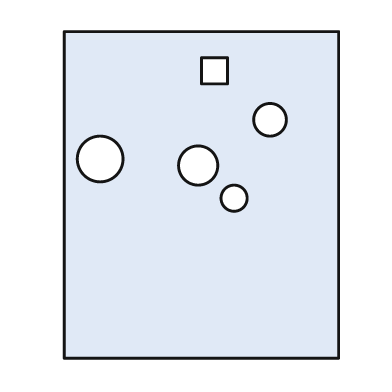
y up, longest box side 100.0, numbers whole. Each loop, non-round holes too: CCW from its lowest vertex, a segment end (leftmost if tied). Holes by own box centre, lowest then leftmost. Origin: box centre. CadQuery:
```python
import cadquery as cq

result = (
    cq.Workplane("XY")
    .moveTo(-42.0, -50.0)
    .lineTo(42.0, -50.0)
    .lineTo(42.0, 50.0)
    .lineTo(-42.0, 50.0)
    .close()
    .moveTo(10.0, -1.0)
    .circle(4.0)
    .moveTo(-1.0, 9.0)
    .circle(6.0)
    .moveTo(-31.0, 11.0)
    .circle(7.0)
    .moveTo(21.0, 23.0)
    .circle(5.0)
    .moveTo(0.0, 34.0)
    .lineTo(8.0, 34.0)
    .lineTo(8.0, 42.0)
    .lineTo(0.0, 42.0)
    .close()
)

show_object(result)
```